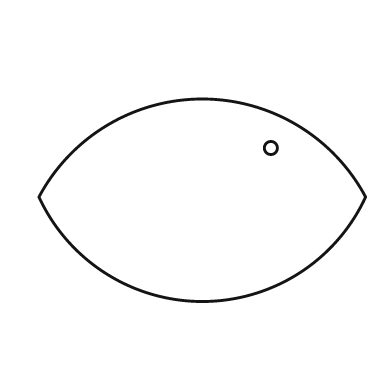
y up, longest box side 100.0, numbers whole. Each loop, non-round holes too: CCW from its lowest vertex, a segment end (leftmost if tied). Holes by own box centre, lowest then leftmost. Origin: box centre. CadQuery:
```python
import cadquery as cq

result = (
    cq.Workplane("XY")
    .moveTo(-50.0, 1.0)
    .threePointArc((0.0, -31.0), (50.0, 1.0))
    .threePointArc((0.0, 31.0), (-50.0, 1.0))
    .close()
    .moveTo(21.0, 16.0)
    .circle(2.0)
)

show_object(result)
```